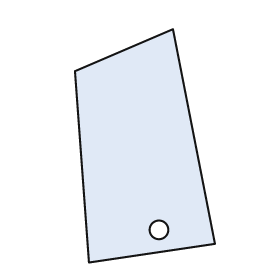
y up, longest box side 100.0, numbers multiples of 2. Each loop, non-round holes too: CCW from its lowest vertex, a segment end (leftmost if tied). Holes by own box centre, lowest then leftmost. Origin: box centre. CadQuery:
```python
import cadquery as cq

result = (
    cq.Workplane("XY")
    .moveTo(-24.0, -50.0)
    .lineTo(30.0, -42.0)
    .lineTo(12.0, 50.0)
    .lineTo(-30.0, 32.0)
    .close()
    .moveTo(6.0, -36.0)
    .circle(4.0)
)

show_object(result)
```